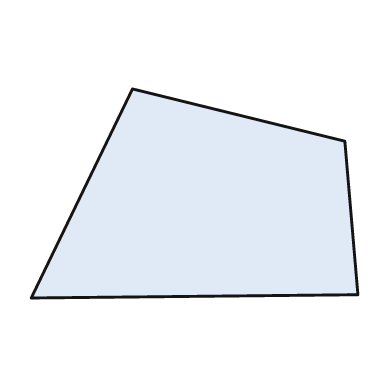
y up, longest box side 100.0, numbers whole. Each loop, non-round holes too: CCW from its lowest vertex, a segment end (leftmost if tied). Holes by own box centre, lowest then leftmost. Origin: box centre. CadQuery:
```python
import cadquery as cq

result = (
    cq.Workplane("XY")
    .moveTo(-50.0, -32.0)
    .lineTo(50.0, -31.0)
    .lineTo(46.0, 16.0)
    .lineTo(-19.0, 32.0)
    .close()
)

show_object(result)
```